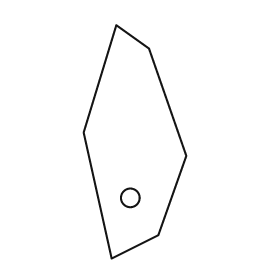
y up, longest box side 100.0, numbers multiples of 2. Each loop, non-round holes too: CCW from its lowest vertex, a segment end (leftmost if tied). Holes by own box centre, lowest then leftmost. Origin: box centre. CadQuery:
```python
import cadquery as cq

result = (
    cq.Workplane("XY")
    .moveTo(-10.0, -50.0)
    .lineTo(10.0, -40.0)
    .lineTo(22.0, -6.0)
    .lineTo(6.0, 40.0)
    .lineTo(-8.0, 50.0)
    .lineTo(-22.0, 4.0)
    .close()
    .moveTo(-2.0, -24.0)
    .circle(4.0)
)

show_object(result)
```